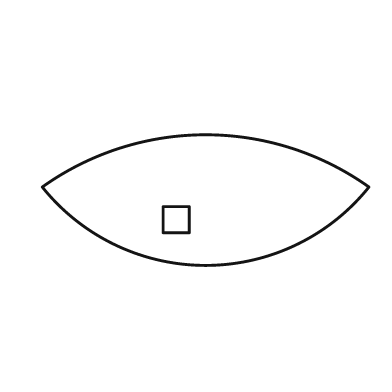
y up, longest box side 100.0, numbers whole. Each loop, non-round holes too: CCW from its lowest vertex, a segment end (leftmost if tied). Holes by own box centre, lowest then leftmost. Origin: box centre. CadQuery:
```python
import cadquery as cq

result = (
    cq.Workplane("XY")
    .moveTo(-50.0, 4.0)
    .threePointArc((0.0, -20.0), (50.0, 4.0))
    .threePointArc((0.0, 20.0), (-50.0, 4.0))
    .close()
    .moveTo(-13.0, -10.0)
    .lineTo(-5.0, -10.0)
    .lineTo(-5.0, -2.0)
    .lineTo(-13.0, -2.0)
    .close()
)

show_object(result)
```